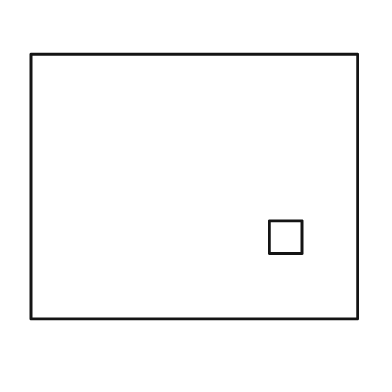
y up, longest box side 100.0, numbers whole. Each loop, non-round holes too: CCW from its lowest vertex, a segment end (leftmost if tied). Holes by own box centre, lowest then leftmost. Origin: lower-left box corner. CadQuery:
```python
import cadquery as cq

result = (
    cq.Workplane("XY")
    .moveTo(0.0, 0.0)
    .lineTo(100.0, 0.0)
    .lineTo(100.0, 81.0)
    .lineTo(0.0, 81.0)
    .close()
    .moveTo(73.0, 20.0)
    .lineTo(83.0, 20.0)
    .lineTo(83.0, 30.0)
    .lineTo(73.0, 30.0)
    .close()
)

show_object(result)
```